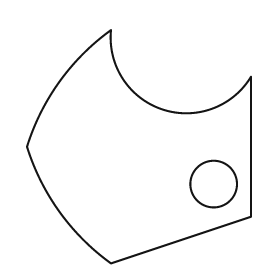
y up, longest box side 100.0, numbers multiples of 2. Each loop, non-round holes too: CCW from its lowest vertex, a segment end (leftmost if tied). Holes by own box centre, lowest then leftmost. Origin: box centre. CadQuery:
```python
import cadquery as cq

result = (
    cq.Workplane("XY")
    .moveTo(-12.0, -50.0)
    .lineTo(48.0, -30.0)
    .lineTo(48.0, 30.0)
    .threePointArc((10.0, 16.0), (-12.0, 50.0))
    .threePointArc((-34.0, 28.0), (-48.0, 0.0))
    .threePointArc((-34.0, -28.0), (-12.0, -50.0))
    .close()
    .moveTo(32.0, -16.0)
    .circle(10.0)
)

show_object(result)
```